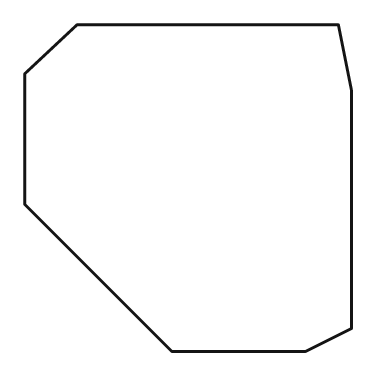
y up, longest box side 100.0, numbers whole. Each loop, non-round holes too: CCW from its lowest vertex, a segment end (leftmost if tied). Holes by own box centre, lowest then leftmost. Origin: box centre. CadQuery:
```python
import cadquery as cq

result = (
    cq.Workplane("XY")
    .moveTo(-5.0, -50.0)
    .lineTo(36.0, -50.0)
    .lineTo(50.0, -43.0)
    .lineTo(50.0, 30.0)
    .lineTo(46.0, 50.0)
    .lineTo(-34.0, 50.0)
    .lineTo(-50.0, 35.0)
    .lineTo(-50.0, -5.0)
    .close()
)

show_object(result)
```